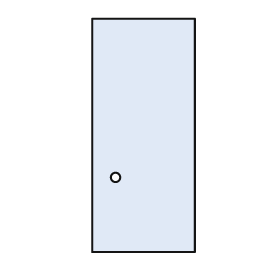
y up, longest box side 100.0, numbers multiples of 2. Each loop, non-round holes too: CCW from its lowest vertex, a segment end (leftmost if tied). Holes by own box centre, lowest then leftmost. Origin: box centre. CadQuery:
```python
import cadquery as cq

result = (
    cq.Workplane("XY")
    .moveTo(-22.0, -50.0)
    .lineTo(22.0, -50.0)
    .lineTo(22.0, 50.0)
    .lineTo(-22.0, 50.0)
    .close()
    .moveTo(-12.0, -18.0)
    .circle(2.0)
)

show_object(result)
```